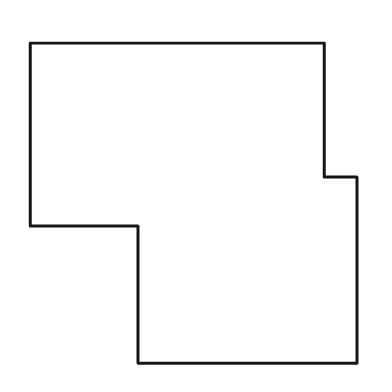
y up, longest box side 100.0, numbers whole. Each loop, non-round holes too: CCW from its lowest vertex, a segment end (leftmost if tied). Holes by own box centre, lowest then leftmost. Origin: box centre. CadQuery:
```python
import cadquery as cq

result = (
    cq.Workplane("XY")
    .moveTo(-17.0, -49.0)
    .lineTo(50.0, -49.0)
    .lineTo(50.0, 8.0)
    .lineTo(40.0, 8.0)
    .lineTo(40.0, 49.0)
    .lineTo(-50.0, 49.0)
    .lineTo(-50.0, -7.0)
    .lineTo(-17.0, -7.0)
    .close()
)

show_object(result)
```